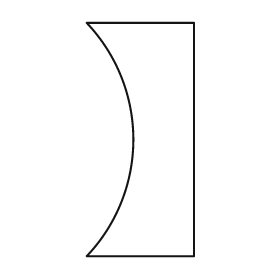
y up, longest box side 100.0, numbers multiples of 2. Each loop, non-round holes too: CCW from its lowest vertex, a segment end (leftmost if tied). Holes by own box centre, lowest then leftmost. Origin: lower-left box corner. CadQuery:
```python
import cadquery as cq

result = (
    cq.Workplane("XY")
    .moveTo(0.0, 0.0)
    .lineTo(46.0, 0.0)
    .lineTo(46.0, 100.0)
    .lineTo(0.0, 100.0)
    .threePointArc((20.0, 50.0), (0.0, 0.0))
    .close()
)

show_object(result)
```